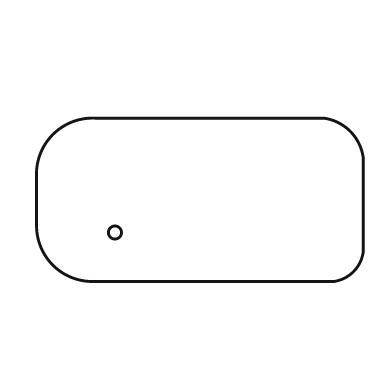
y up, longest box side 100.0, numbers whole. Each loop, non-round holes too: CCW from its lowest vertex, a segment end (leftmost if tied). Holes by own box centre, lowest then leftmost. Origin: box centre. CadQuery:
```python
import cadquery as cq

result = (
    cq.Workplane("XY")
    .moveTo(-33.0, -25.0)
    .lineTo(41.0, -25.0)
    .threePointArc((47.0, -22.0), (50.0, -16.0))
    .lineTo(50.0, 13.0)
    .threePointArc((46.0, 21.0), (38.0, 25.0))
    .lineTo(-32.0, 25.0)
    .threePointArc((-45.0, 20.0), (-50.0, 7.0))
    .lineTo(-50.0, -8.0)
    .threePointArc((-45.0, -20.0), (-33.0, -25.0))
    .close()
    .moveTo(-26.0, -10.0)
    .circle(2.0)
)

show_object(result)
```